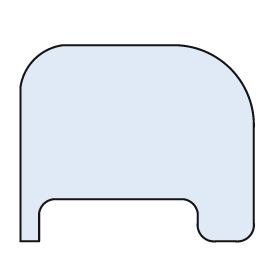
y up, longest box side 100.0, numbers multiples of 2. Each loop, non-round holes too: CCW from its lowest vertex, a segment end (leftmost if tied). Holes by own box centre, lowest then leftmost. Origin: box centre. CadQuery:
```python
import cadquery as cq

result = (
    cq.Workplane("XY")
    .moveTo(-50.0, -42.0)
    .lineTo(-42.0, -42.0)
    .lineTo(-42.0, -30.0)
    .threePointArc((-40.0, -26.0), (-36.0, -24.0))
    .lineTo(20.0, -24.0)
    .threePointArc((24.0, -26.0), (26.0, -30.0))
    .lineTo(26.0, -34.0)
    .threePointArc((28.0, -40.0), (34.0, -42.0))
    .lineTo(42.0, -42.0)
    .threePointArc((48.0, -40.0), (50.0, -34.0))
    .lineTo(50.0, 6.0)
    .threePointArc((40.0, 32.0), (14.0, 42.0))
    .lineTo(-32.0, 42.0)
    .threePointArc((-44.0, 36.0), (-50.0, 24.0))
    .close()
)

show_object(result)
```